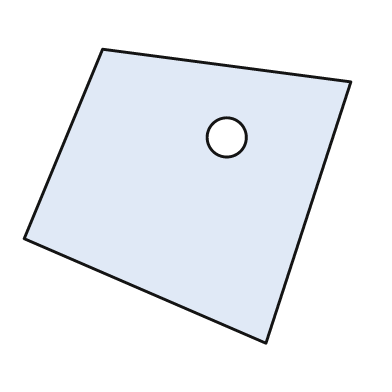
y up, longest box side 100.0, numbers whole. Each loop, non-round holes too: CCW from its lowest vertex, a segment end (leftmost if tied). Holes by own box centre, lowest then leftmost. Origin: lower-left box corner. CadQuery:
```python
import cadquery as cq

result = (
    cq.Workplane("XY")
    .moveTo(74.0, 0.0)
    .lineTo(100.0, 80.0)
    .lineTo(24.0, 90.0)
    .lineTo(0.0, 32.0)
    .close()
    .moveTo(62.0, 63.0)
    .circle(6.0)
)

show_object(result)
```